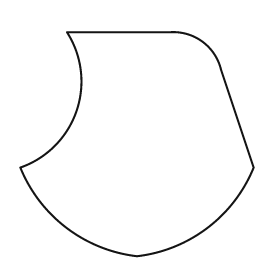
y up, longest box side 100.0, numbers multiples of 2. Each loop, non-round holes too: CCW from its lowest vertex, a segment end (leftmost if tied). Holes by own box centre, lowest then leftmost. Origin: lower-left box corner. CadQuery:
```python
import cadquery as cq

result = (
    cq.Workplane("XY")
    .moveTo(50.0, 0.0)
    .threePointArc((80.0, 12.0), (100.0, 38.0))
    .lineTo(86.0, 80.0)
    .threePointArc((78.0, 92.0), (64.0, 96.0))
    .lineTo(20.0, 96.0)
    .threePointArc((24.0, 62.0), (0.0, 38.0))
    .threePointArc((20.0, 12.0), (50.0, 0.0))
    .close()
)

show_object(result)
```